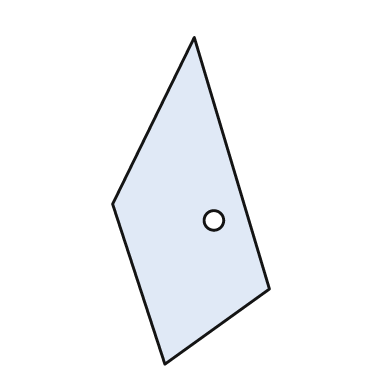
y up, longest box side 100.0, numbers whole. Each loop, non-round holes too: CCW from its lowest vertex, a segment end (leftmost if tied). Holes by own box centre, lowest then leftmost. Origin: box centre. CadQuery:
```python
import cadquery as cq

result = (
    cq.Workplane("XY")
    .moveTo(-8.0, -50.0)
    .lineTo(24.0, -27.0)
    .lineTo(1.0, 50.0)
    .lineTo(-24.0, -1.0)
    .close()
    .moveTo(7.0, -6.0)
    .circle(3.0)
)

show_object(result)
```